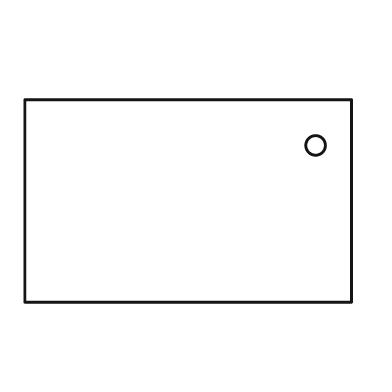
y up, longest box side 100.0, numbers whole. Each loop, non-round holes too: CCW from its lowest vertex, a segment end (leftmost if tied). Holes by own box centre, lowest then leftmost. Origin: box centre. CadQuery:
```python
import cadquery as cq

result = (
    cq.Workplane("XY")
    .moveTo(-50.0, -31.0)
    .lineTo(50.0, -31.0)
    .lineTo(50.0, 31.0)
    .lineTo(-50.0, 31.0)
    .close()
    .moveTo(39.0, 17.0)
    .circle(3.0)
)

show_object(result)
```